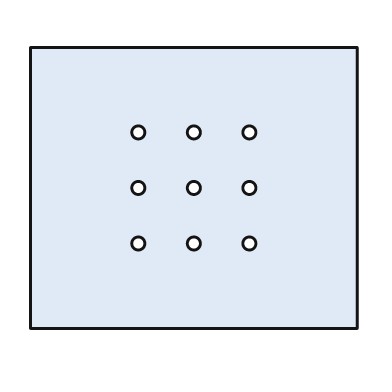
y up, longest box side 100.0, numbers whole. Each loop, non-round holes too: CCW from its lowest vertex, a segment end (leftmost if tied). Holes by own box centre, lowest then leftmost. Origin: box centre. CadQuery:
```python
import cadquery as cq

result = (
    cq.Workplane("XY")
    .moveTo(-50.0, -43.0)
    .lineTo(50.0, -43.0)
    .lineTo(50.0, 43.0)
    .lineTo(-50.0, 43.0)
    .close()
    .moveTo(-17.0, -17.0)
    .circle(2.0)
    .moveTo(0.0, -17.0)
    .circle(2.0)
    .moveTo(17.0, -17.0)
    .circle(2.0)
    .moveTo(-17.0, 0.0)
    .circle(2.0)
    .moveTo(0.0, 0.0)
    .circle(2.0)
    .moveTo(17.0, 0.0)
    .circle(2.0)
    .moveTo(-17.0, 17.0)
    .circle(2.0)
    .moveTo(0.0, 17.0)
    .circle(2.0)
    .moveTo(17.0, 17.0)
    .circle(2.0)
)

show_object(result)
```